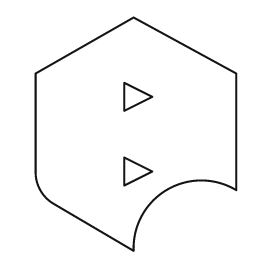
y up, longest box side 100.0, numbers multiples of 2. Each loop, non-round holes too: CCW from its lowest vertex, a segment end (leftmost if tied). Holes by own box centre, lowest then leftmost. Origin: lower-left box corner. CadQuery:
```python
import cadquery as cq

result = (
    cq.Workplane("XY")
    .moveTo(42.0, 0.0)
    .threePointArc((56.0, 26.0), (86.0, 26.0))
    .lineTo(86.0, 76.0)
    .lineTo(42.0, 100.0)
    .lineTo(0.0, 76.0)
    .lineTo(0.0, 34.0)
    .threePointArc((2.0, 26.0), (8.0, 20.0))
    .close()
    .moveTo(38.0, 28.0)
    .lineTo(50.0, 34.0)
    .lineTo(38.0, 40.0)
    .close()
    .moveTo(38.0, 60.0)
    .lineTo(50.0, 66.0)
    .lineTo(38.0, 72.0)
    .close()
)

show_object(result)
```